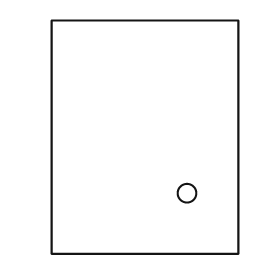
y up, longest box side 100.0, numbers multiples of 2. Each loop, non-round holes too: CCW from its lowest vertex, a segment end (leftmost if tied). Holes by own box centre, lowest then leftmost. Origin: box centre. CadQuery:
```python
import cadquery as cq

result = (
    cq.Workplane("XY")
    .moveTo(-40.0, -50.0)
    .lineTo(40.0, -50.0)
    .lineTo(40.0, 50.0)
    .lineTo(-40.0, 50.0)
    .close()
    .moveTo(18.0, -24.0)
    .circle(4.0)
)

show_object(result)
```